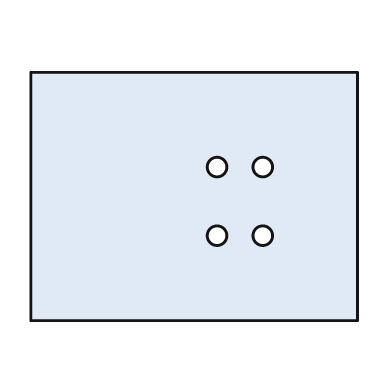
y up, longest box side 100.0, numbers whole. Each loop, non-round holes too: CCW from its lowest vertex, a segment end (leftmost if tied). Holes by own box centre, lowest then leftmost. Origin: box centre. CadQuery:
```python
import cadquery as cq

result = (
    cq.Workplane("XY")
    .moveTo(-50.0, -38.0)
    .lineTo(50.0, -38.0)
    .lineTo(50.0, 38.0)
    .lineTo(-50.0, 38.0)
    .close()
    .moveTo(7.0, -12.0)
    .circle(3.0)
    .moveTo(21.0, -12.0)
    .circle(3.0)
    .moveTo(7.0, 9.0)
    .circle(3.0)
    .moveTo(21.0, 9.0)
    .circle(3.0)
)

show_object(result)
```